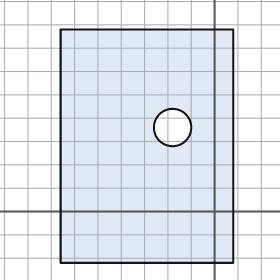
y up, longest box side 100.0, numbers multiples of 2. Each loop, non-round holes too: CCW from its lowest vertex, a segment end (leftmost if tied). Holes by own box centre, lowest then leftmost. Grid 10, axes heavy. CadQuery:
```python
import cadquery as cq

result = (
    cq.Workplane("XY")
    .moveTo(-66.0, -22.0)
    .lineTo(8.0, -22.0)
    .lineTo(8.0, 78.0)
    .lineTo(-66.0, 78.0)
    .close()
    .moveTo(-18.0, 36.0)
    .circle(8.0)
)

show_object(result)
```